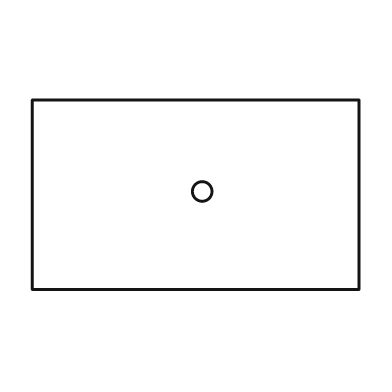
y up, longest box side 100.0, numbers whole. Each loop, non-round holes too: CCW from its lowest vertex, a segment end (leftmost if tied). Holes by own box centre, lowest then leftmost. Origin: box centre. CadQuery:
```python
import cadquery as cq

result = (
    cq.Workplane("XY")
    .moveTo(-50.0, -29.0)
    .lineTo(50.0, -29.0)
    .lineTo(50.0, 29.0)
    .lineTo(-50.0, 29.0)
    .close()
    .moveTo(2.0, 1.0)
    .circle(3.0)
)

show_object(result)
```